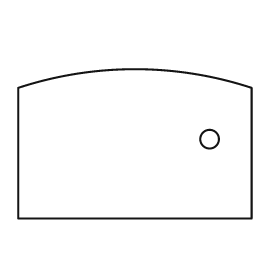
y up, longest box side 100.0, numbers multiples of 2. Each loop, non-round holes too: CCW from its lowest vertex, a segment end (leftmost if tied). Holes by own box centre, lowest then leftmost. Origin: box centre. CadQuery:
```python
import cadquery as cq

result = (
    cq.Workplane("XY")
    .moveTo(-50.0, -32.0)
    .lineTo(50.0, -32.0)
    .lineTo(50.0, 24.0)
    .threePointArc((0.0, 32.0), (-50.0, 24.0))
    .close()
    .moveTo(32.0, 2.0)
    .circle(4.0)
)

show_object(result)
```